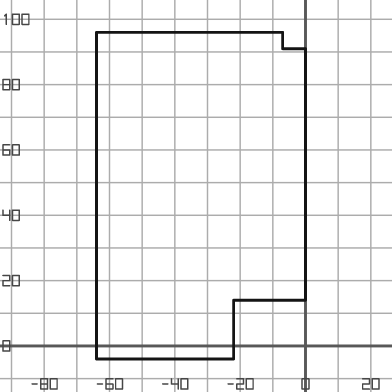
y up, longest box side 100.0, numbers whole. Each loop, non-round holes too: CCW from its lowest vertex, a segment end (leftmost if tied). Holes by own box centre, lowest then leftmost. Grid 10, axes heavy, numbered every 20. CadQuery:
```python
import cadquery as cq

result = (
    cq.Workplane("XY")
    .moveTo(-64.0, -4.0)
    .lineTo(-22.0, -4.0)
    .lineTo(-22.0, 14.0)
    .lineTo(0.0, 14.0)
    .lineTo(0.0, 91.0)
    .lineTo(-7.0, 91.0)
    .lineTo(-7.0, 96.0)
    .lineTo(-64.0, 96.0)
    .close()
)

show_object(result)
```